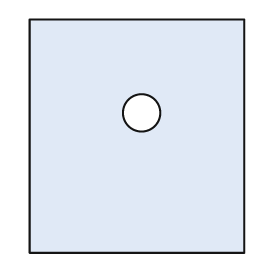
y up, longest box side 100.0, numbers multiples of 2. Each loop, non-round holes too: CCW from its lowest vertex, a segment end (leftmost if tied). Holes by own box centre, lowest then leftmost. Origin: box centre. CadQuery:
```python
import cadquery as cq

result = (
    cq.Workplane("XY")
    .moveTo(-46.0, -50.0)
    .lineTo(46.0, -50.0)
    .lineTo(46.0, 50.0)
    .lineTo(-46.0, 50.0)
    .close()
    .moveTo(2.0, 10.0)
    .circle(8.0)
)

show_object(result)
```